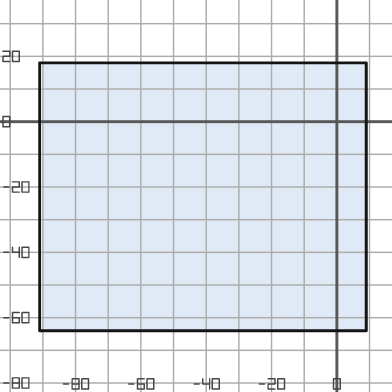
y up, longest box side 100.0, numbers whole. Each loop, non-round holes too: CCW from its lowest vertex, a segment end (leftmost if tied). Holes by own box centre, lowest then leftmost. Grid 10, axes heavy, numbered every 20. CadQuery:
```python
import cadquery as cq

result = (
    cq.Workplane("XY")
    .moveTo(-91.0, -64.0)
    .lineTo(9.0, -64.0)
    .lineTo(9.0, 18.0)
    .lineTo(-91.0, 18.0)
    .close()
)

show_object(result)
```